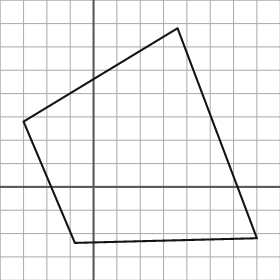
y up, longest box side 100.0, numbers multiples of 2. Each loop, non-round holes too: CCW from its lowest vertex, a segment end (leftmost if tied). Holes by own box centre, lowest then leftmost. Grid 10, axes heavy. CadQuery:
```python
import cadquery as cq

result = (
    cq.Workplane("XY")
    .moveTo(-8.0, -24.0)
    .lineTo(70.0, -22.0)
    .lineTo(36.0, 68.0)
    .lineTo(-30.0, 28.0)
    .close()
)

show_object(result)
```